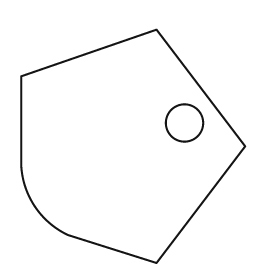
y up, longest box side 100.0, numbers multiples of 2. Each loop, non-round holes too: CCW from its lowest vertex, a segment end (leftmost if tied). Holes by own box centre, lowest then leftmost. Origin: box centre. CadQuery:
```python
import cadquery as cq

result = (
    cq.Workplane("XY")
    .moveTo(10.0, -50.0)
    .lineTo(48.0, 0.0)
    .lineTo(10.0, 50.0)
    .lineTo(-48.0, 30.0)
    .lineTo(-48.0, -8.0)
    .threePointArc((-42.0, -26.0), (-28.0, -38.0))
    .close()
    .moveTo(22.0, 10.0)
    .circle(8.0)
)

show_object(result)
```